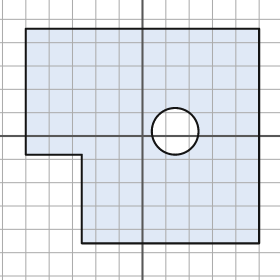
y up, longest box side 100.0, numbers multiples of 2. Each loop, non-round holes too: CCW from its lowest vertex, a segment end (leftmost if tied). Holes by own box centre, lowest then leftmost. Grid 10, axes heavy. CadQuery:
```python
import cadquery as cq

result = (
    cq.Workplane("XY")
    .moveTo(-26.0, -46.0)
    .lineTo(50.0, -46.0)
    .lineTo(50.0, 46.0)
    .lineTo(-50.0, 46.0)
    .lineTo(-50.0, -8.0)
    .lineTo(-26.0, -8.0)
    .close()
    .moveTo(14.0, 2.0)
    .circle(10.0)
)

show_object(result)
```